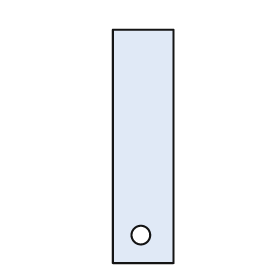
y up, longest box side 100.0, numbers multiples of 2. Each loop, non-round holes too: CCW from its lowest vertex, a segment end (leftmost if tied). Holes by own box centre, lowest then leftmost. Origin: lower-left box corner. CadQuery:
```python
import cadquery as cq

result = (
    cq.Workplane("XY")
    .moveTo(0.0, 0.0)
    .lineTo(26.0, 0.0)
    .lineTo(26.0, 100.0)
    .lineTo(0.0, 100.0)
    .close()
    .moveTo(12.0, 12.0)
    .circle(4.0)
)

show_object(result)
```